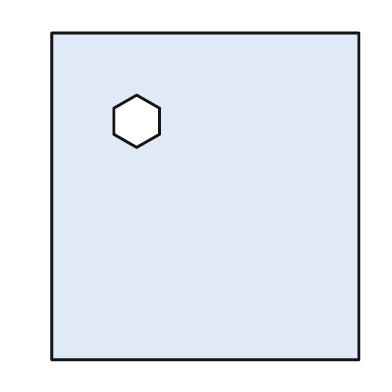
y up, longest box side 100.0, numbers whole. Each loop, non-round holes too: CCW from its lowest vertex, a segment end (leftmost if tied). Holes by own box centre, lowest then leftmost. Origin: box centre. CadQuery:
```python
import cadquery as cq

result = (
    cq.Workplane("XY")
    .moveTo(-47.0, -50.0)
    .lineTo(47.0, -50.0)
    .lineTo(47.0, 50.0)
    .lineTo(-47.0, 50.0)
    .close()
    .moveTo(-21.0, 15.0)
    .lineTo(-14.0, 19.0)
    .lineTo(-14.0, 27.0)
    .lineTo(-21.0, 31.0)
    .lineTo(-28.0, 27.0)
    .lineTo(-28.0, 19.0)
    .close()
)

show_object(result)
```